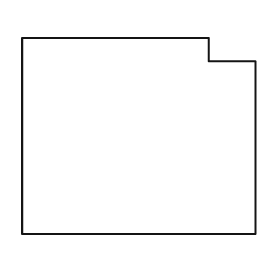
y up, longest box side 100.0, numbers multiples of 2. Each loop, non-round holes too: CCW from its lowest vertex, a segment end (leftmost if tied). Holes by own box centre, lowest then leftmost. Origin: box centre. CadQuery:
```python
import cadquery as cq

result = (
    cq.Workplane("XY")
    .moveTo(-50.0, -42.0)
    .lineTo(50.0, -42.0)
    .lineTo(50.0, 32.0)
    .lineTo(30.0, 32.0)
    .lineTo(30.0, 42.0)
    .lineTo(-50.0, 42.0)
    .close()
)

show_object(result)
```